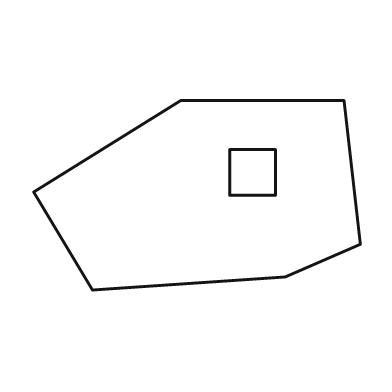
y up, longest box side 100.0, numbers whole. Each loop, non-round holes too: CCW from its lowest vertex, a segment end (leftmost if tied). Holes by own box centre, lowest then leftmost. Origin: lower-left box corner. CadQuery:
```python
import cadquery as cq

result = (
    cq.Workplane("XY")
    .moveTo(18.0, 0.0)
    .lineTo(77.0, 4.0)
    .lineTo(100.0, 14.0)
    .lineTo(95.0, 58.0)
    .lineTo(45.0, 58.0)
    .lineTo(0.0, 30.0)
    .close()
    .moveTo(60.0, 29.0)
    .lineTo(74.0, 29.0)
    .lineTo(74.0, 43.0)
    .lineTo(60.0, 43.0)
    .close()
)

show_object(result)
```